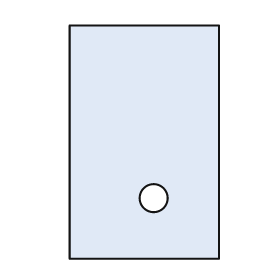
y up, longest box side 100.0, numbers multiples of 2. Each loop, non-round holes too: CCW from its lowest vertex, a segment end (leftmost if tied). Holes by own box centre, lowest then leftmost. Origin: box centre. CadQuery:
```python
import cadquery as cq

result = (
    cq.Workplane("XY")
    .moveTo(-32.0, -50.0)
    .lineTo(32.0, -50.0)
    .lineTo(32.0, 50.0)
    .lineTo(-32.0, 50.0)
    .close()
    .moveTo(4.0, -24.0)
    .circle(6.0)
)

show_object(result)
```